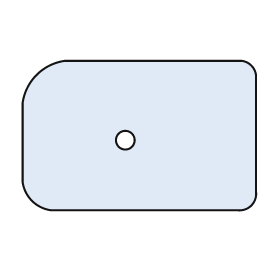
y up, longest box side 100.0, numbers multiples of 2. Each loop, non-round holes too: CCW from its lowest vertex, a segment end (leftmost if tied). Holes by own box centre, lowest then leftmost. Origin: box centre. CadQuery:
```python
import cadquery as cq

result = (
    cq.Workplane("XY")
    .moveTo(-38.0, -32.0)
    .lineTo(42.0, -32.0)
    .threePointArc((48.0, -30.0), (50.0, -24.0))
    .lineTo(50.0, 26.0)
    .threePointArc((48.0, 30.0), (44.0, 32.0))
    .lineTo(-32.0, 32.0)
    .threePointArc((-44.0, 26.0), (-50.0, 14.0))
    .lineTo(-50.0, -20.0)
    .threePointArc((-46.0, -28.0), (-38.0, -32.0))
    .close()
    .moveTo(-6.0, -2.0)
    .circle(4.0)
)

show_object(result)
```